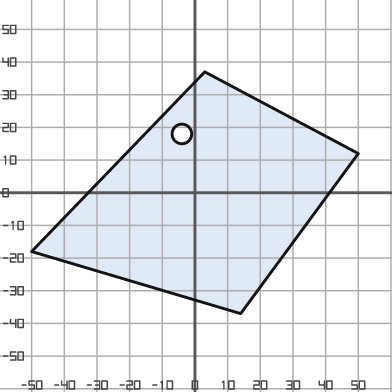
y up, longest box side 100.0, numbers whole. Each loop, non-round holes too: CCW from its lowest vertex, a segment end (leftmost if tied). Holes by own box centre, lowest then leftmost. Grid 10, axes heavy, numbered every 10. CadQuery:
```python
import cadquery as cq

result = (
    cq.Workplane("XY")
    .moveTo(14.0, -37.0)
    .lineTo(50.0, 12.0)
    .lineTo(3.0, 37.0)
    .lineTo(-50.0, -18.0)
    .close()
    .moveTo(-4.0, 18.0)
    .circle(3.0)
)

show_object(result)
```